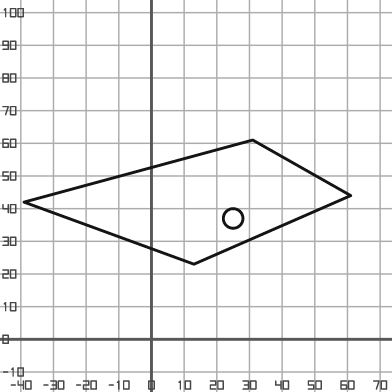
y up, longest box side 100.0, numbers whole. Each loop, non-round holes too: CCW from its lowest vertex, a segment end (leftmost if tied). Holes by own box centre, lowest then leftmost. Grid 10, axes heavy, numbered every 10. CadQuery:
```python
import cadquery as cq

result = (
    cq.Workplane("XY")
    .moveTo(13.0, 23.0)
    .lineTo(61.0, 44.0)
    .lineTo(31.0, 61.0)
    .lineTo(-39.0, 42.0)
    .close()
    .moveTo(25.0, 37.0)
    .circle(3.0)
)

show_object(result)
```